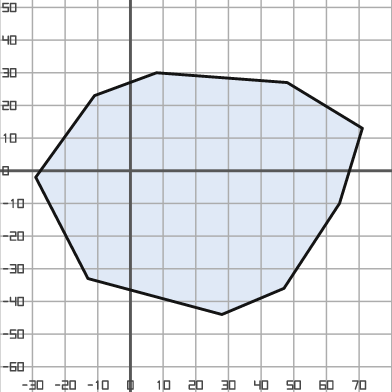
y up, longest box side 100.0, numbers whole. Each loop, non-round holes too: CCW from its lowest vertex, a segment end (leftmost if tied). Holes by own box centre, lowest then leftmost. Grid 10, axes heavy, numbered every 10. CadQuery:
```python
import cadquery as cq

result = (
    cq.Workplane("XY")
    .moveTo(28.0, -44.0)
    .lineTo(47.0, -36.0)
    .lineTo(64.0, -10.0)
    .lineTo(71.0, 13.0)
    .lineTo(48.0, 27.0)
    .lineTo(8.0, 30.0)
    .lineTo(-11.0, 23.0)
    .lineTo(-29.0, -2.0)
    .lineTo(-13.0, -33.0)
    .close()
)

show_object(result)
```